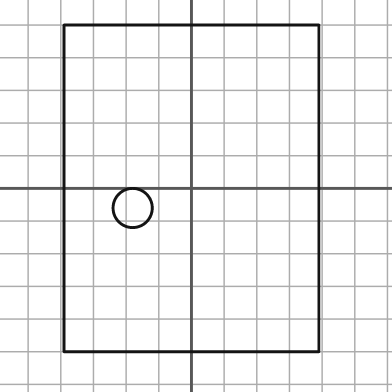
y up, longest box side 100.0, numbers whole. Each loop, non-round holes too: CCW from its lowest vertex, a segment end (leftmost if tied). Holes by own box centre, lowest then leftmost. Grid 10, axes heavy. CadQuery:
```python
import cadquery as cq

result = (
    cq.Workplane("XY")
    .moveTo(-39.0, -50.0)
    .lineTo(39.0, -50.0)
    .lineTo(39.0, 50.0)
    .lineTo(-39.0, 50.0)
    .close()
    .moveTo(-18.0, -6.0)
    .circle(6.0)
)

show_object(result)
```